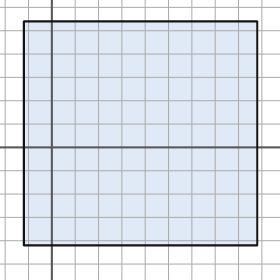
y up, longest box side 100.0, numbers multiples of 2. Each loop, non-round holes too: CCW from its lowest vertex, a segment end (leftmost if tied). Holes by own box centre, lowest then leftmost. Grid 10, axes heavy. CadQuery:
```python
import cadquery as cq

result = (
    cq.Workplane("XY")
    .moveTo(-12.0, -42.0)
    .lineTo(88.0, -42.0)
    .lineTo(88.0, 54.0)
    .lineTo(-12.0, 54.0)
    .close()
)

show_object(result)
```